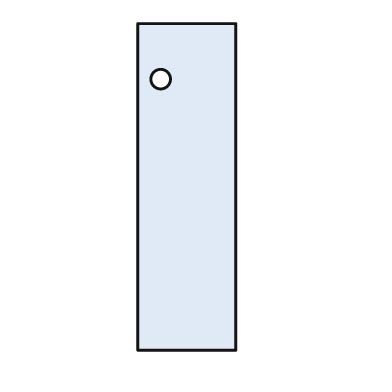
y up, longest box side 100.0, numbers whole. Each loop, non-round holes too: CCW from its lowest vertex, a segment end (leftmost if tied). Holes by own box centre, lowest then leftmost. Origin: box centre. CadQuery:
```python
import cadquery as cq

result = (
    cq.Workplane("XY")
    .moveTo(-15.0, -50.0)
    .lineTo(15.0, -50.0)
    .lineTo(15.0, 50.0)
    .lineTo(-15.0, 50.0)
    .close()
    .moveTo(-8.0, 33.0)
    .circle(3.0)
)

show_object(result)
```